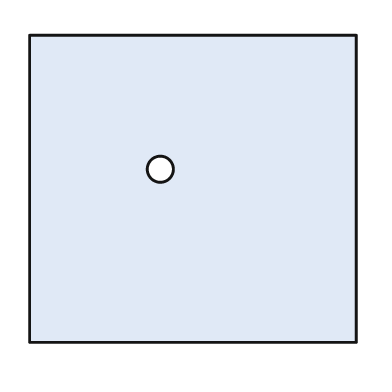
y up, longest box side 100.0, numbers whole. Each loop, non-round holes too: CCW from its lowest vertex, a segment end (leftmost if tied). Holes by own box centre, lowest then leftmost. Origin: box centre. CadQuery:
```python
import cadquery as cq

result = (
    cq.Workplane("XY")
    .moveTo(-50.0, -47.0)
    .lineTo(50.0, -47.0)
    .lineTo(50.0, 47.0)
    .lineTo(-50.0, 47.0)
    .close()
    .moveTo(-10.0, 6.0)
    .circle(4.0)
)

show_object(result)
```